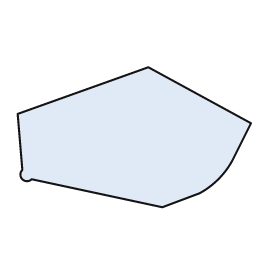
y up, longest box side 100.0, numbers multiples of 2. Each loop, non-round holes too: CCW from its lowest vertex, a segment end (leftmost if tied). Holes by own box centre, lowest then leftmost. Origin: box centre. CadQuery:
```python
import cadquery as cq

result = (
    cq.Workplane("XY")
    .moveTo(12.0, -30.0)
    .lineTo(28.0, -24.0)
    .threePointArc((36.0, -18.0), (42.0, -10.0))
    .lineTo(50.0, 6.0)
    .lineTo(6.0, 30.0)
    .lineTo(-50.0, 10.0)
    .lineTo(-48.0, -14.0)
    .threePointArc((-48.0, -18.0), (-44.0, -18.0))
    .close()
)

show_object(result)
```